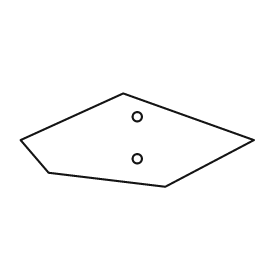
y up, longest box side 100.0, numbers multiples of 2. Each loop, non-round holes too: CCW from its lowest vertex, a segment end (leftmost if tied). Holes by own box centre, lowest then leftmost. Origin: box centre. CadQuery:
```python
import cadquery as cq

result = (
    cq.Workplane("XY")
    .moveTo(12.0, -20.0)
    .lineTo(50.0, 0.0)
    .lineTo(-6.0, 20.0)
    .lineTo(-50.0, 0.0)
    .lineTo(-38.0, -14.0)
    .close()
    .moveTo(0.0, -8.0)
    .circle(2.0)
    .moveTo(0.0, 10.0)
    .circle(2.0)
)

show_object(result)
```